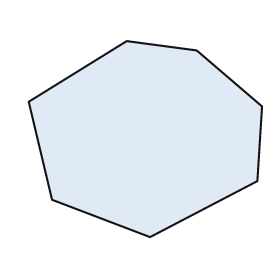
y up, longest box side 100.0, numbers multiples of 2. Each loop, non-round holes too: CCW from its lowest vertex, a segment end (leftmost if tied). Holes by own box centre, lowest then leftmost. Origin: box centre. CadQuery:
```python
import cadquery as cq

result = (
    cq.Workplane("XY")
    .moveTo(2.0, -42.0)
    .lineTo(48.0, -18.0)
    .lineTo(50.0, 14.0)
    .lineTo(22.0, 38.0)
    .lineTo(-8.0, 42.0)
    .lineTo(-50.0, 16.0)
    .lineTo(-40.0, -26.0)
    .close()
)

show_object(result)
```